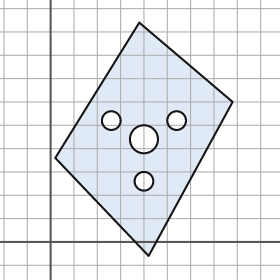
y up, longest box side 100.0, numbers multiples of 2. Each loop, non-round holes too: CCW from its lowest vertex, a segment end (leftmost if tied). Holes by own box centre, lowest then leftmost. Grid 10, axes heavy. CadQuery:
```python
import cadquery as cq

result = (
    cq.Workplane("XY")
    .moveTo(42.0, -6.0)
    .lineTo(78.0, 60.0)
    .lineTo(38.0, 94.0)
    .lineTo(2.0, 36.0)
    .close()
    .moveTo(40.0, 26.0)
    .circle(4.0)
    .moveTo(40.0, 44.0)
    .circle(6.0)
    .moveTo(26.0, 52.0)
    .circle(4.0)
    .moveTo(54.0, 52.0)
    .circle(4.0)
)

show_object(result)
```